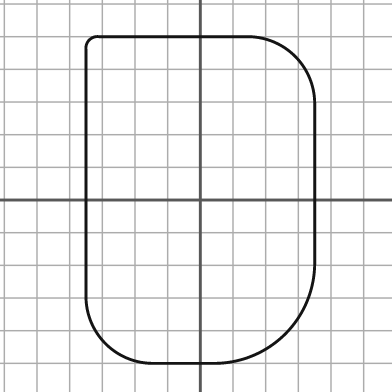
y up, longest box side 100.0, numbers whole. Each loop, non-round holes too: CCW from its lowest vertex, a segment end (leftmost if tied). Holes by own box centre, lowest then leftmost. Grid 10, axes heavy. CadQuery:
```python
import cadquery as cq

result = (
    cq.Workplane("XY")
    .moveTo(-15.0, -50.0)
    .lineTo(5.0, -50.0)
    .threePointArc((26.0, -41.0), (35.0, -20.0))
    .lineTo(35.0, 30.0)
    .threePointArc((29.0, 44.0), (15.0, 50.0))
    .lineTo(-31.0, 50.0)
    .threePointArc((-34.0, 49.0), (-35.0, 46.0))
    .lineTo(-35.0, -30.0)
    .threePointArc((-29.0, -44.0), (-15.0, -50.0))
    .close()
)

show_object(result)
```